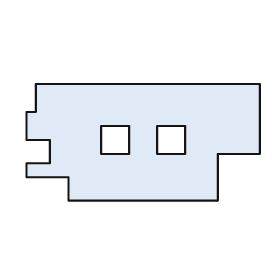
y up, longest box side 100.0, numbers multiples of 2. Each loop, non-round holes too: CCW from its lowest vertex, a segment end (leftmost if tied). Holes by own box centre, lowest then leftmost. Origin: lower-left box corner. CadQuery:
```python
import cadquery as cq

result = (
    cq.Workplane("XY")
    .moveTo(18.0, 0.0)
    .lineTo(82.0, 0.0)
    .lineTo(82.0, 20.0)
    .lineTo(100.0, 20.0)
    .lineTo(100.0, 50.0)
    .lineTo(4.0, 50.0)
    .lineTo(4.0, 38.0)
    .lineTo(0.0, 38.0)
    .lineTo(0.0, 26.0)
    .lineTo(10.0, 26.0)
    .lineTo(10.0, 16.0)
    .lineTo(0.0, 16.0)
    .lineTo(0.0, 10.0)
    .lineTo(18.0, 10.0)
    .close()
    .moveTo(32.0, 20.0)
    .lineTo(44.0, 20.0)
    .lineTo(44.0, 32.0)
    .lineTo(32.0, 32.0)
    .close()
    .moveTo(56.0, 20.0)
    .lineTo(68.0, 20.0)
    .lineTo(68.0, 32.0)
    .lineTo(56.0, 32.0)
    .close()
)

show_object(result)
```